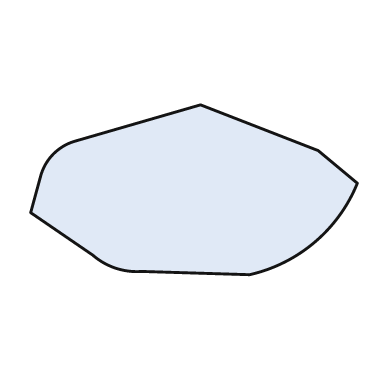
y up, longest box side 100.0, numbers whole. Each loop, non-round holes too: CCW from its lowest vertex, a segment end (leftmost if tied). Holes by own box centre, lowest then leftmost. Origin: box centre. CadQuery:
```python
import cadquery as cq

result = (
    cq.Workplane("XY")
    .moveTo(17.0, -26.0)
    .threePointArc((37.0, -16.0), (50.0, 2.0))
    .lineTo(38.0, 12.0)
    .lineTo(2.0, 26.0)
    .lineTo(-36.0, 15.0)
    .threePointArc((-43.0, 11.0), (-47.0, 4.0))
    .lineTo(-50.0, -7.0)
    .lineTo(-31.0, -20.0)
    .threePointArc((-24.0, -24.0), (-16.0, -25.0))
    .close()
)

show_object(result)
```